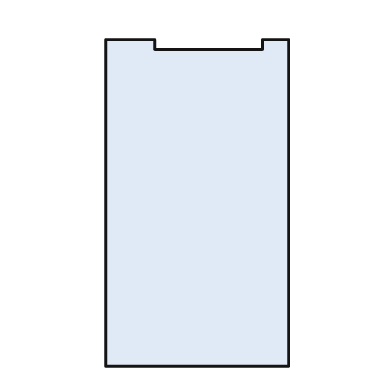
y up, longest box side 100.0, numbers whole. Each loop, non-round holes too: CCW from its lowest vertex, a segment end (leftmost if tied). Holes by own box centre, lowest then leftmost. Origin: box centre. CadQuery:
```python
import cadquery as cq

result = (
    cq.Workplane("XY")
    .moveTo(-28.0, -50.0)
    .lineTo(28.0, -50.0)
    .lineTo(28.0, 50.0)
    .lineTo(20.0, 50.0)
    .lineTo(20.0, 47.0)
    .lineTo(-13.0, 47.0)
    .lineTo(-13.0, 50.0)
    .lineTo(-28.0, 50.0)
    .close()
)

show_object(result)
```